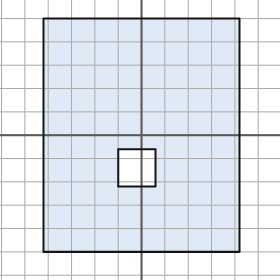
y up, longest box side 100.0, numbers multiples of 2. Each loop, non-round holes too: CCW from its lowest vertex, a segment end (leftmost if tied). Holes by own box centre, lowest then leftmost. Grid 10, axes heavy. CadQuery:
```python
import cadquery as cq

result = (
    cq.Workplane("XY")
    .moveTo(-42.0, -50.0)
    .lineTo(42.0, -50.0)
    .lineTo(42.0, 50.0)
    .lineTo(-42.0, 50.0)
    .close()
    .moveTo(-10.0, -22.0)
    .lineTo(6.0, -22.0)
    .lineTo(6.0, -6.0)
    .lineTo(-10.0, -6.0)
    .close()
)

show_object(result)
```